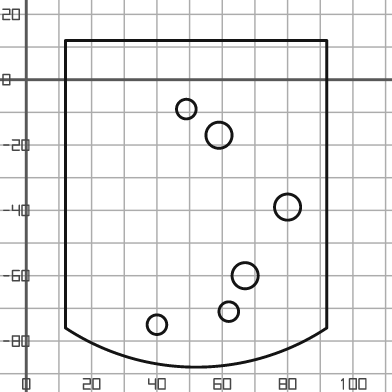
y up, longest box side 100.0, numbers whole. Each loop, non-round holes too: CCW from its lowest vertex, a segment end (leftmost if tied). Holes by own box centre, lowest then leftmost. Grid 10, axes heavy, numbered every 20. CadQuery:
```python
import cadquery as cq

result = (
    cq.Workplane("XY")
    .moveTo(12.0, -76.0)
    .threePointArc((52.0, -88.0), (92.0, -76.0))
    .lineTo(92.0, 12.0)
    .lineTo(12.0, 12.0)
    .close()
    .moveTo(40.0, -75.0)
    .circle(3.0)
    .moveTo(62.0, -71.0)
    .circle(3.0)
    .moveTo(67.0, -60.0)
    .circle(4.0)
    .moveTo(80.0, -39.0)
    .circle(4.0)
    .moveTo(59.0, -17.0)
    .circle(4.0)
    .moveTo(49.0, -9.0)
    .circle(3.0)
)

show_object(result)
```